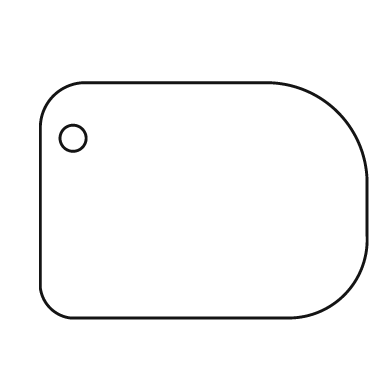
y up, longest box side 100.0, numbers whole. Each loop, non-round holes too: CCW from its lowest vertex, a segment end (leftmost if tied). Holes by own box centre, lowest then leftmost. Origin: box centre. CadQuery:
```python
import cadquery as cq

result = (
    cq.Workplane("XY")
    .moveTo(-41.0, -36.0)
    .lineTo(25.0, -36.0)
    .threePointArc((43.0, -29.0), (50.0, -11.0))
    .lineTo(50.0, 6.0)
    .threePointArc((41.0, 27.0), (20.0, 36.0))
    .lineTo(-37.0, 36.0)
    .threePointArc((-46.0, 32.0), (-50.0, 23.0))
    .lineTo(-50.0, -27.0)
    .threePointArc((-47.0, -33.0), (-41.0, -36.0))
    .close()
    .moveTo(-40.0, 19.0)
    .circle(4.0)
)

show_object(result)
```